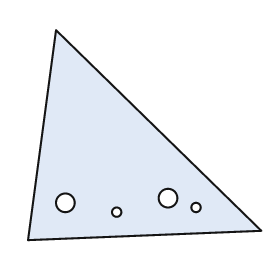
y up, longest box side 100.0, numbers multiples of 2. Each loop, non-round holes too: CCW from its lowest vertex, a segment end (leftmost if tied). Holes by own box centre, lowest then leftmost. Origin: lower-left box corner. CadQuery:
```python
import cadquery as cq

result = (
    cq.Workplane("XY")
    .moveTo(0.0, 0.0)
    .lineTo(100.0, 4.0)
    .lineTo(12.0, 90.0)
    .close()
    .moveTo(38.0, 12.0)
    .circle(2.0)
    .moveTo(72.0, 14.0)
    .circle(2.0)
    .moveTo(16.0, 16.0)
    .circle(4.0)
    .moveTo(60.0, 18.0)
    .circle(4.0)
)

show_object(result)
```